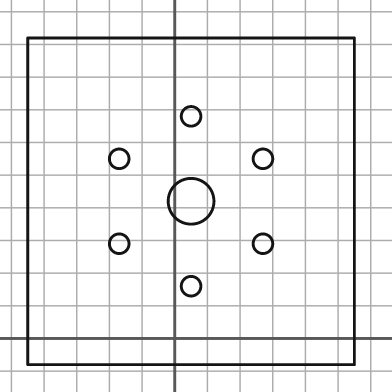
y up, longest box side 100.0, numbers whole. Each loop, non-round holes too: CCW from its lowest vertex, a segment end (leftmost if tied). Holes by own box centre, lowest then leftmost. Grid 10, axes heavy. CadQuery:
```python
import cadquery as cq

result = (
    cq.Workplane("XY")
    .moveTo(-45.0, -8.0)
    .lineTo(55.0, -8.0)
    .lineTo(55.0, 92.0)
    .lineTo(-45.0, 92.0)
    .close()
    .moveTo(5.0, 16.0)
    .circle(3.0)
    .moveTo(-17.0, 29.0)
    .circle(3.0)
    .moveTo(27.0, 29.0)
    .circle(3.0)
    .moveTo(5.0, 42.0)
    .circle(7.0)
    .moveTo(-17.0, 55.0)
    .circle(3.0)
    .moveTo(27.0, 55.0)
    .circle(3.0)
    .moveTo(5.0, 68.0)
    .circle(3.0)
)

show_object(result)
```